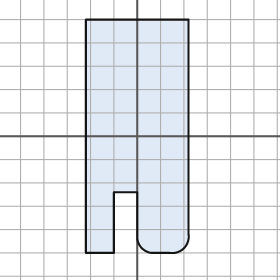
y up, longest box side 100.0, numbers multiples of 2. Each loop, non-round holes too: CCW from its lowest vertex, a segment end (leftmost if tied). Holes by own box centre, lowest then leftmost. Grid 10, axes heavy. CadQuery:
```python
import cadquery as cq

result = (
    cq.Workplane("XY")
    .moveTo(-22.0, -50.0)
    .lineTo(-10.0, -50.0)
    .lineTo(-10.0, -24.0)
    .lineTo(0.0, -24.0)
    .lineTo(0.0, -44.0)
    .threePointArc((2.0, -48.0), (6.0, -50.0))
    .lineTo(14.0, -50.0)
    .threePointArc((20.0, -48.0), (22.0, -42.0))
    .lineTo(22.0, 50.0)
    .lineTo(-22.0, 50.0)
    .close()
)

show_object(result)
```